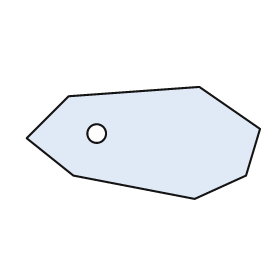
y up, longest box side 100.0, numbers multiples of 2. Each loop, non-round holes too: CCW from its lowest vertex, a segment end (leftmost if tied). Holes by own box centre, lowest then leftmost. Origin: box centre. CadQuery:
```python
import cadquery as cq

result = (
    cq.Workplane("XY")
    .moveTo(22.0, -24.0)
    .lineTo(44.0, -14.0)
    .lineTo(50.0, 6.0)
    .lineTo(24.0, 24.0)
    .lineTo(-32.0, 20.0)
    .lineTo(-50.0, 2.0)
    .lineTo(-30.0, -14.0)
    .close()
    .moveTo(-20.0, 4.0)
    .circle(4.0)
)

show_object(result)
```